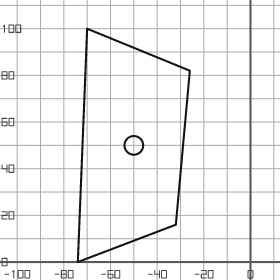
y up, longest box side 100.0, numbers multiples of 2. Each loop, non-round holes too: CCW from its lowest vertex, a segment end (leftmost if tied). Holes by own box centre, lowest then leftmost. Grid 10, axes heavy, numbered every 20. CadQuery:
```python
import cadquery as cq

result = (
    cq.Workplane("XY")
    .moveTo(-74.0, 0.0)
    .lineTo(-32.0, 16.0)
    .lineTo(-26.0, 82.0)
    .lineTo(-70.0, 100.0)
    .close()
    .moveTo(-50.0, 50.0)
    .circle(4.0)
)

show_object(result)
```